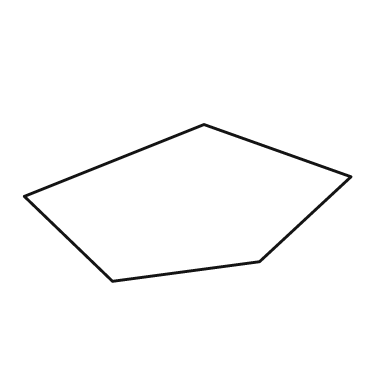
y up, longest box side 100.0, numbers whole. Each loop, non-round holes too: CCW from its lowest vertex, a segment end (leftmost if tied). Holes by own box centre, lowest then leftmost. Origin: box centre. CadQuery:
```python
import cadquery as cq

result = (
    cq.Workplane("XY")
    .moveTo(-23.0, -24.0)
    .lineTo(22.0, -18.0)
    .lineTo(50.0, 8.0)
    .lineTo(5.0, 24.0)
    .lineTo(-50.0, 2.0)
    .close()
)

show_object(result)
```